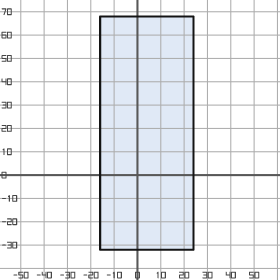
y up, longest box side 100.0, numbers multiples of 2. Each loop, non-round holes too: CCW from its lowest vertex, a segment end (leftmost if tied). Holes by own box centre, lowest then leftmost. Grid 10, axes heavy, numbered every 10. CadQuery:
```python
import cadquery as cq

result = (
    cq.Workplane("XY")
    .moveTo(-16.0, -32.0)
    .lineTo(24.0, -32.0)
    .lineTo(24.0, 68.0)
    .lineTo(-16.0, 68.0)
    .close()
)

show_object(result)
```